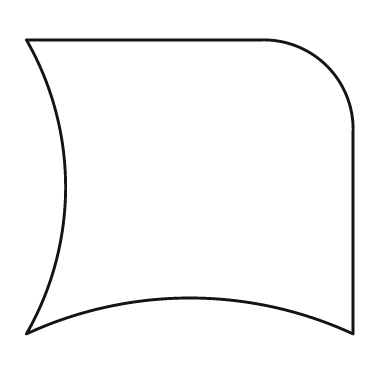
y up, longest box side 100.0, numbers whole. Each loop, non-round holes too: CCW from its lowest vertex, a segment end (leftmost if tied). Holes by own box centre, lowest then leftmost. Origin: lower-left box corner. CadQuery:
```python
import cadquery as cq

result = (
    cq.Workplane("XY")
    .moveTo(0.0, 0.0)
    .threePointArc((50.0, 11.0), (100.0, 0.0))
    .lineTo(100.0, 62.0)
    .threePointArc((92.0, 82.0), (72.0, 90.0))
    .lineTo(0.0, 90.0)
    .threePointArc((12.0, 45.0), (0.0, 0.0))
    .close()
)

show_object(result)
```